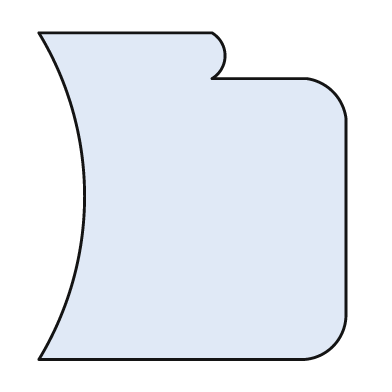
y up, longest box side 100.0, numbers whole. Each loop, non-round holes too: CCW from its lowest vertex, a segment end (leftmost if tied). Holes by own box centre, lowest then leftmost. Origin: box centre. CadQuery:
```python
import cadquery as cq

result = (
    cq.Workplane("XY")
    .moveTo(-47.0, -50.0)
    .lineTo(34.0, -50.0)
    .threePointArc((43.0, -46.0), (47.0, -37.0))
    .lineTo(47.0, 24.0)
    .threePointArc((43.0, 32.0), (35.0, 36.0))
    .lineTo(6.0, 36.0)
    .threePointArc((10.0, 43.0), (6.0, 50.0))
    .lineTo(-47.0, 50.0)
    .threePointArc((-33.0, 0.0), (-47.0, -50.0))
    .close()
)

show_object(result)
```